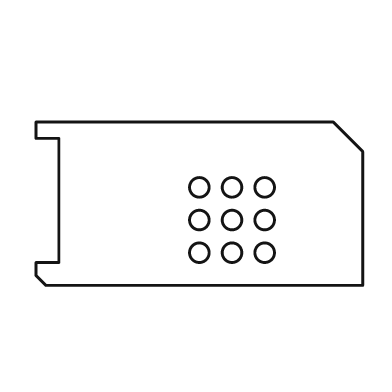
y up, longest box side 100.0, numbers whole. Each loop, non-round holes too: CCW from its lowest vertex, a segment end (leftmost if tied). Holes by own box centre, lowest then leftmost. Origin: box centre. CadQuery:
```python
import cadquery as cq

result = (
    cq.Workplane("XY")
    .moveTo(-47.0, -25.0)
    .lineTo(50.0, -25.0)
    .lineTo(50.0, 16.0)
    .lineTo(41.0, 25.0)
    .lineTo(-50.0, 25.0)
    .lineTo(-50.0, 20.0)
    .lineTo(-43.0, 20.0)
    .lineTo(-43.0, -18.0)
    .lineTo(-50.0, -18.0)
    .lineTo(-50.0, -22.0)
    .close()
    .moveTo(0.0, -15.0)
    .circle(3.0)
    .moveTo(10.0, -15.0)
    .circle(3.0)
    .moveTo(20.0, -15.0)
    .circle(3.0)
    .moveTo(0.0, -5.0)
    .circle(3.0)
    .moveTo(10.0, -5.0)
    .circle(3.0)
    .moveTo(20.0, -5.0)
    .circle(3.0)
    .moveTo(0.0, 5.0)
    .circle(3.0)
    .moveTo(10.0, 5.0)
    .circle(3.0)
    .moveTo(20.0, 5.0)
    .circle(3.0)
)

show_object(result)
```